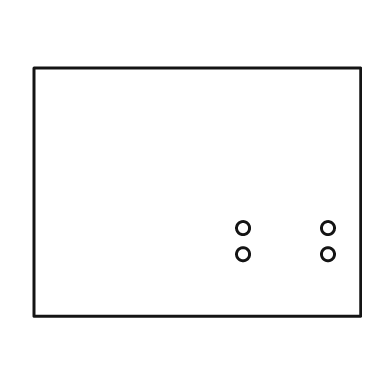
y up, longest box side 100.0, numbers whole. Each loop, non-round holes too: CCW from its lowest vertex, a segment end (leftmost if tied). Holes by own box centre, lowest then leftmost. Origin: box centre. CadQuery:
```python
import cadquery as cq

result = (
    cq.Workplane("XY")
    .moveTo(-50.0, -38.0)
    .lineTo(50.0, -38.0)
    .lineTo(50.0, 38.0)
    .lineTo(-50.0, 38.0)
    .close()
    .moveTo(14.0, -19.0)
    .circle(2.0)
    .moveTo(40.0, -19.0)
    .circle(2.0)
    .moveTo(14.0, -11.0)
    .circle(2.0)
    .moveTo(40.0, -11.0)
    .circle(2.0)
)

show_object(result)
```